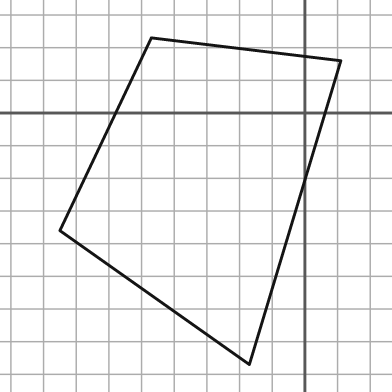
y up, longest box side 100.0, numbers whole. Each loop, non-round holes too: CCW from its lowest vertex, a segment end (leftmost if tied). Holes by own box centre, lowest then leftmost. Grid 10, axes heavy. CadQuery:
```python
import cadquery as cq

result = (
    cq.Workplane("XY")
    .moveTo(-17.0, -77.0)
    .lineTo(11.0, 16.0)
    .lineTo(-47.0, 23.0)
    .lineTo(-75.0, -36.0)
    .close()
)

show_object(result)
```